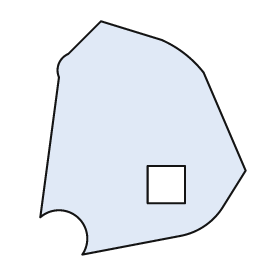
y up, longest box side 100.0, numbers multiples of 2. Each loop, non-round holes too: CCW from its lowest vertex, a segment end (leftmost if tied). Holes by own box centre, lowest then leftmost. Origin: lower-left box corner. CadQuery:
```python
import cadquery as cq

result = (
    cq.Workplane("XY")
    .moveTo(18.0, 0.0)
    .lineTo(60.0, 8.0)
    .threePointArc((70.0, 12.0), (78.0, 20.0))
    .lineTo(88.0, 36.0)
    .lineTo(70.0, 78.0)
    .threePointArc((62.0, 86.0), (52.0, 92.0))
    .lineTo(26.0, 100.0)
    .lineTo(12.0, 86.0)
    .threePointArc((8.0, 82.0), (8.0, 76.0))
    .lineTo(0.0, 16.0)
    .threePointArc((16.0, 16.0), (18.0, 0.0))
    .close()
    .moveTo(46.0, 22.0)
    .lineTo(62.0, 22.0)
    .lineTo(62.0, 38.0)
    .lineTo(46.0, 38.0)
    .close()
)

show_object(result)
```